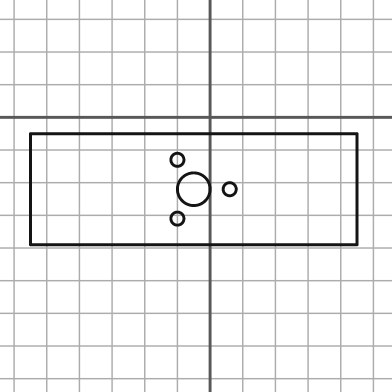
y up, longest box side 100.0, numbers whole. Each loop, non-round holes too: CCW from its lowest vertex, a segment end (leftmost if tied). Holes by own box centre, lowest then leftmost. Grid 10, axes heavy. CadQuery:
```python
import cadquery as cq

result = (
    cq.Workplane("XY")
    .moveTo(-55.0, -39.0)
    .lineTo(45.0, -39.0)
    .lineTo(45.0, -5.0)
    .lineTo(-55.0, -5.0)
    .close()
    .moveTo(-10.0, -31.0)
    .circle(2.0)
    .moveTo(-5.0, -22.0)
    .circle(5.0)
    .moveTo(6.0, -22.0)
    .circle(2.0)
    .moveTo(-10.0, -13.0)
    .circle(2.0)
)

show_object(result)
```